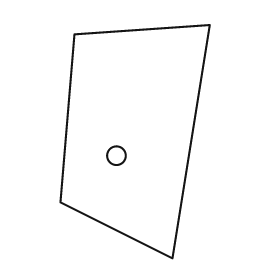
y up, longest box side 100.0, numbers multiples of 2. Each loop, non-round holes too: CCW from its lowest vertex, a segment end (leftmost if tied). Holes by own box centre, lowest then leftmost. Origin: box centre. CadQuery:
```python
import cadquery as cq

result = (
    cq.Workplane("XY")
    .moveTo(16.0, -50.0)
    .lineTo(32.0, 50.0)
    .lineTo(-26.0, 46.0)
    .lineTo(-32.0, -26.0)
    .close()
    .moveTo(-8.0, -6.0)
    .circle(4.0)
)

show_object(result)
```